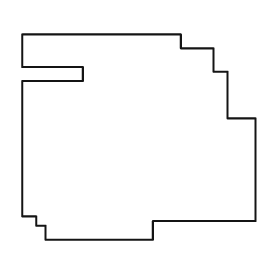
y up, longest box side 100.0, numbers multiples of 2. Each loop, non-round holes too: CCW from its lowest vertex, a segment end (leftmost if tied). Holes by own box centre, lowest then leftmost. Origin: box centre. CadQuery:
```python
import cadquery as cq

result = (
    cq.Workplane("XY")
    .moveTo(-40.0, -44.0)
    .lineTo(6.0, -44.0)
    .lineTo(6.0, -36.0)
    .lineTo(50.0, -36.0)
    .lineTo(50.0, 8.0)
    .lineTo(38.0, 8.0)
    .lineTo(38.0, 28.0)
    .lineTo(32.0, 28.0)
    .lineTo(32.0, 38.0)
    .lineTo(18.0, 38.0)
    .lineTo(18.0, 44.0)
    .lineTo(-50.0, 44.0)
    .lineTo(-50.0, 30.0)
    .lineTo(-24.0, 30.0)
    .lineTo(-24.0, 24.0)
    .lineTo(-50.0, 24.0)
    .lineTo(-50.0, -34.0)
    .lineTo(-44.0, -34.0)
    .lineTo(-44.0, -38.0)
    .lineTo(-40.0, -38.0)
    .close()
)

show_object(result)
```